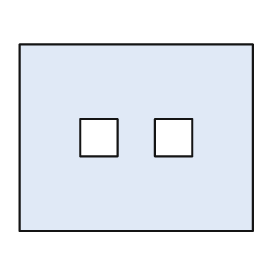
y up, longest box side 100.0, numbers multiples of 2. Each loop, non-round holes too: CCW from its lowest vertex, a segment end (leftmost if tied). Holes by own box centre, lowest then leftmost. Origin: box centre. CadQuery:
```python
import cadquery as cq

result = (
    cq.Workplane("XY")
    .moveTo(-50.0, -40.0)
    .lineTo(50.0, -40.0)
    .lineTo(50.0, 40.0)
    .lineTo(-50.0, 40.0)
    .close()
    .moveTo(-24.0, -8.0)
    .lineTo(-8.0, -8.0)
    .lineTo(-8.0, 8.0)
    .lineTo(-24.0, 8.0)
    .close()
    .moveTo(8.0, -8.0)
    .lineTo(24.0, -8.0)
    .lineTo(24.0, 8.0)
    .lineTo(8.0, 8.0)
    .close()
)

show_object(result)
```